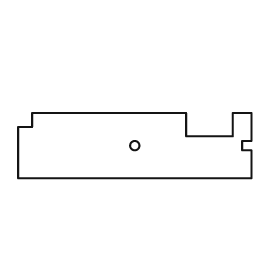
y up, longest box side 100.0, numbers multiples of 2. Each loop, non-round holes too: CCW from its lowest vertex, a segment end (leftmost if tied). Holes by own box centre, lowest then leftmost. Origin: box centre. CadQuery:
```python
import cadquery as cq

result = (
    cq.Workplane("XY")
    .moveTo(-50.0, -14.0)
    .lineTo(50.0, -14.0)
    .lineTo(50.0, -2.0)
    .lineTo(46.0, -2.0)
    .lineTo(46.0, 2.0)
    .lineTo(50.0, 2.0)
    .lineTo(50.0, 14.0)
    .lineTo(42.0, 14.0)
    .lineTo(42.0, 4.0)
    .lineTo(22.0, 4.0)
    .lineTo(22.0, 14.0)
    .lineTo(-44.0, 14.0)
    .lineTo(-44.0, 8.0)
    .lineTo(-50.0, 8.0)
    .close()
    .moveTo(0.0, 0.0)
    .circle(2.0)
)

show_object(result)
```